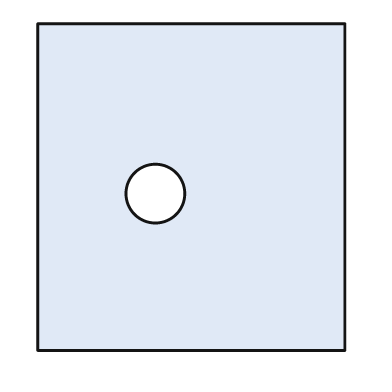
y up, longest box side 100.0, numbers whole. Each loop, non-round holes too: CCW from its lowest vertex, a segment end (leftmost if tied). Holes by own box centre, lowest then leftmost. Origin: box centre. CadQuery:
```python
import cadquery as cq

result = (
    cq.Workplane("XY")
    .moveTo(-47.0, -50.0)
    .lineTo(47.0, -50.0)
    .lineTo(47.0, 50.0)
    .lineTo(-47.0, 50.0)
    .close()
    .moveTo(-11.0, -2.0)
    .circle(9.0)
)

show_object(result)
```